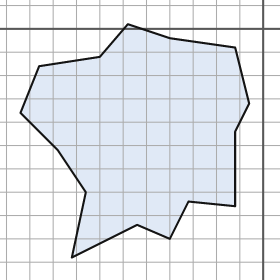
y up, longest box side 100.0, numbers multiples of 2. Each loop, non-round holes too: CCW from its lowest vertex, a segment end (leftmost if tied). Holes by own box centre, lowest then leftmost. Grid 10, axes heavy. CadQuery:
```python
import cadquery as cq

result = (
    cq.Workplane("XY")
    .moveTo(-82.0, -98.0)
    .lineTo(-54.0, -84.0)
    .lineTo(-40.0, -90.0)
    .lineTo(-32.0, -74.0)
    .lineTo(-12.0, -76.0)
    .lineTo(-12.0, -44.0)
    .lineTo(-6.0, -32.0)
    .lineTo(-12.0, -8.0)
    .lineTo(-40.0, -4.0)
    .lineTo(-58.0, 2.0)
    .lineTo(-70.0, -12.0)
    .lineTo(-96.0, -16.0)
    .lineTo(-104.0, -36.0)
    .lineTo(-88.0, -52.0)
    .lineTo(-76.0, -70.0)
    .close()
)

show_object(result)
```